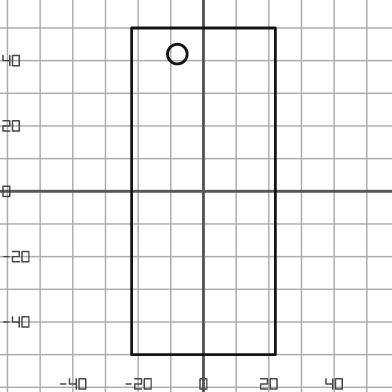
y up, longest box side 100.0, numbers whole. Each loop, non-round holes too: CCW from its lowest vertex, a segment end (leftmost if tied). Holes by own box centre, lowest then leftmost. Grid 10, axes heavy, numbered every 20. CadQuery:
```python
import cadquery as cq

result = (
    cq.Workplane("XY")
    .moveTo(-22.0, -50.0)
    .lineTo(22.0, -50.0)
    .lineTo(22.0, 50.0)
    .lineTo(-22.0, 50.0)
    .close()
    .moveTo(-8.0, 42.0)
    .circle(3.0)
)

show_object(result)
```